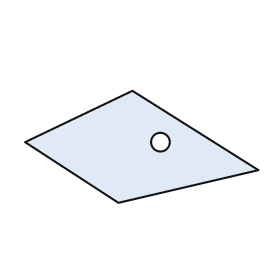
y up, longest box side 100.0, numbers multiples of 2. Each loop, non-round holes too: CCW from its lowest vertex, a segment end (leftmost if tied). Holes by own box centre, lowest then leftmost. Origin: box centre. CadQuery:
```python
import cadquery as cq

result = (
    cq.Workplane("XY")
    .moveTo(-10.0, -24.0)
    .lineTo(50.0, -10.0)
    .lineTo(-4.0, 24.0)
    .lineTo(-50.0, 2.0)
    .close()
    .moveTo(8.0, 2.0)
    .circle(4.0)
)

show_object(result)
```